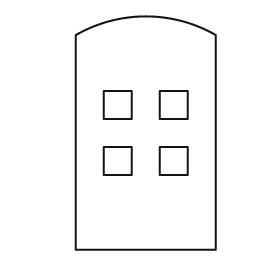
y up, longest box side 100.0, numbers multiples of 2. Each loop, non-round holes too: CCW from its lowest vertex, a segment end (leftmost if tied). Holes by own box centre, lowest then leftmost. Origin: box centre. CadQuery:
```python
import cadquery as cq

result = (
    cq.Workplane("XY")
    .moveTo(-30.0, -50.0)
    .lineTo(30.0, -50.0)
    .lineTo(30.0, 42.0)
    .threePointArc((0.0, 50.0), (-30.0, 42.0))
    .close()
    .moveTo(-18.0, -18.0)
    .lineTo(-6.0, -18.0)
    .lineTo(-6.0, -6.0)
    .lineTo(-18.0, -6.0)
    .close()
    .moveTo(6.0, -18.0)
    .lineTo(18.0, -18.0)
    .lineTo(18.0, -6.0)
    .lineTo(6.0, -6.0)
    .close()
    .moveTo(-18.0, 6.0)
    .lineTo(-6.0, 6.0)
    .lineTo(-6.0, 18.0)
    .lineTo(-18.0, 18.0)
    .close()
    .moveTo(6.0, 6.0)
    .lineTo(18.0, 6.0)
    .lineTo(18.0, 18.0)
    .lineTo(6.0, 18.0)
    .close()
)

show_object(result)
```